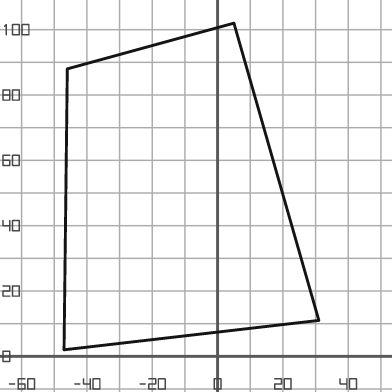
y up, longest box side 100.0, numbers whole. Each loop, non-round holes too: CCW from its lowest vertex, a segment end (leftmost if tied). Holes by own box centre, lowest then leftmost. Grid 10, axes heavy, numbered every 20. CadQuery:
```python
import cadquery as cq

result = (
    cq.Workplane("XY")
    .moveTo(-47.0, 2.0)
    .lineTo(31.0, 11.0)
    .lineTo(5.0, 102.0)
    .lineTo(-46.0, 88.0)
    .close()
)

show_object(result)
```